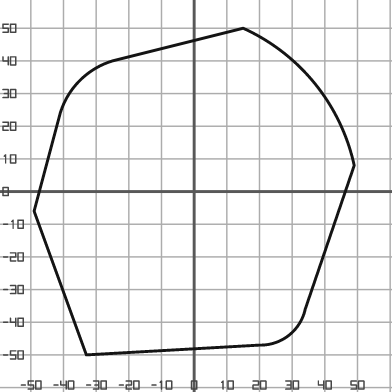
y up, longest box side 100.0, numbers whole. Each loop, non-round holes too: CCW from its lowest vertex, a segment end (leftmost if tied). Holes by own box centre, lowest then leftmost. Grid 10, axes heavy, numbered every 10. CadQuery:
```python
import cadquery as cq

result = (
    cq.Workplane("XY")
    .moveTo(-33.0, -50.0)
    .lineTo(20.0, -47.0)
    .threePointArc((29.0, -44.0), (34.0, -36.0))
    .lineTo(49.0, 8.0)
    .threePointArc((37.0, 33.0), (15.0, 50.0))
    .lineTo(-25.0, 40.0)
    .threePointArc((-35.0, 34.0), (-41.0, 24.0))
    .lineTo(-49.0, -6.0)
    .close()
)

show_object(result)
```